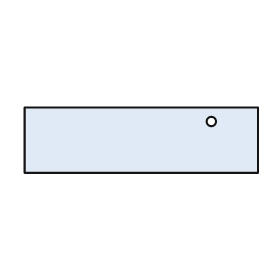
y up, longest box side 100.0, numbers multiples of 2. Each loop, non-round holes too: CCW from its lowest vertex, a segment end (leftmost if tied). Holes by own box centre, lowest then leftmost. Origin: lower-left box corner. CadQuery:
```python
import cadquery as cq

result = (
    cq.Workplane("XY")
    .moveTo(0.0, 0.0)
    .lineTo(100.0, 0.0)
    .lineTo(100.0, 28.0)
    .lineTo(0.0, 28.0)
    .close()
    .moveTo(80.0, 22.0)
    .circle(2.0)
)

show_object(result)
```